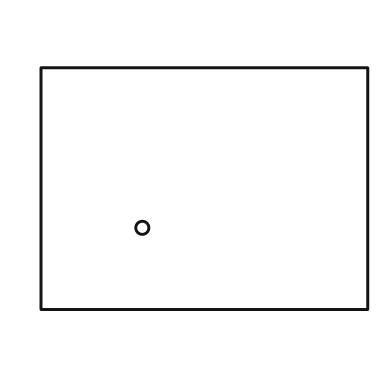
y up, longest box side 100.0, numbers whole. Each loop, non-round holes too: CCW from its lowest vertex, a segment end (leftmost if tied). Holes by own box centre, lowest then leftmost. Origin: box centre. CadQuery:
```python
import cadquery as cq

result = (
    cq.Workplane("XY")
    .moveTo(-50.0, -37.0)
    .lineTo(50.0, -37.0)
    .lineTo(50.0, 37.0)
    .lineTo(-50.0, 37.0)
    .close()
    .moveTo(-19.0, -12.0)
    .circle(2.0)
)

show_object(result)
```